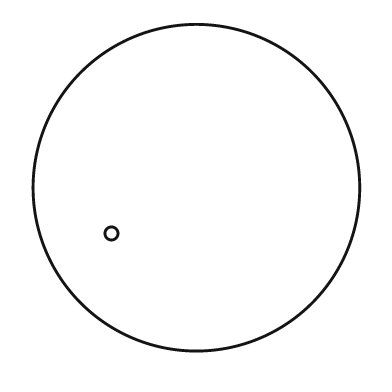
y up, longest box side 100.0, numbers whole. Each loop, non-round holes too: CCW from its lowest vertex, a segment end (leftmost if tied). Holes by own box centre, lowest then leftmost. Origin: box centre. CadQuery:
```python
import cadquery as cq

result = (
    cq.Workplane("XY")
    .moveTo(0.0, 0.0)
    .circle(50.0)
    .moveTo(-26.0, -14.0)
    .circle(2.0)
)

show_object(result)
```